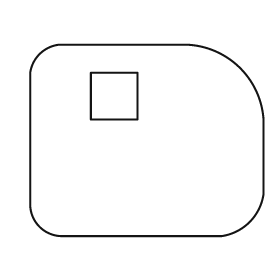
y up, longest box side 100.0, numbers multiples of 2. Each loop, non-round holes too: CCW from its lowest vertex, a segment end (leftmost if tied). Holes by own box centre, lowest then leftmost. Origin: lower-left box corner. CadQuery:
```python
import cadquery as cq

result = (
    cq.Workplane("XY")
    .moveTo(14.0, 0.0)
    .lineTo(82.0, 0.0)
    .threePointArc((94.0, 6.0), (100.0, 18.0))
    .lineTo(100.0, 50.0)
    .threePointArc((90.0, 72.0), (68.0, 82.0))
    .lineTo(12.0, 82.0)
    .threePointArc((4.0, 78.0), (0.0, 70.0))
    .lineTo(0.0, 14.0)
    .threePointArc((4.0, 4.0), (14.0, 0.0))
    .close()
    .moveTo(26.0, 50.0)
    .lineTo(46.0, 50.0)
    .lineTo(46.0, 70.0)
    .lineTo(26.0, 70.0)
    .close()
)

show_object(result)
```